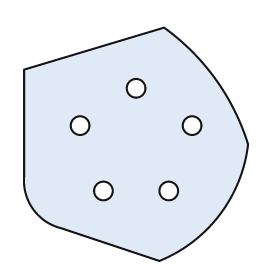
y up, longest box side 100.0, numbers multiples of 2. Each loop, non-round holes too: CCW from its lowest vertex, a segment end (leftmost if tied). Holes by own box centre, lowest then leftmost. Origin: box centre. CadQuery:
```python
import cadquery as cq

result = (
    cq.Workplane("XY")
    .moveTo(10.0, -50.0)
    .threePointArc((36.0, -30.0), (48.0, 0.0))
    .threePointArc((34.0, 28.0), (12.0, 50.0))
    .lineTo(-48.0, 32.0)
    .lineTo(-48.0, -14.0)
    .threePointArc((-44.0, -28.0), (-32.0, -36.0))
    .close()
    .moveTo(-14.0, -20.0)
    .circle(4.0)
    .moveTo(14.0, -20.0)
    .circle(4.0)
    .moveTo(-24.0, 8.0)
    .circle(4.0)
    .moveTo(24.0, 8.0)
    .circle(4.0)
    .moveTo(0.0, 24.0)
    .circle(4.0)
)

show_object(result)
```